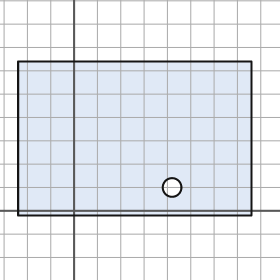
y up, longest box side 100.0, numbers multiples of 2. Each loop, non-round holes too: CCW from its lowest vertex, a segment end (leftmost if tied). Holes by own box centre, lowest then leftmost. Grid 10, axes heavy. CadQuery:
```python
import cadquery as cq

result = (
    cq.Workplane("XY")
    .moveTo(-24.0, -2.0)
    .lineTo(76.0, -2.0)
    .lineTo(76.0, 64.0)
    .lineTo(-24.0, 64.0)
    .close()
    .moveTo(42.0, 10.0)
    .circle(4.0)
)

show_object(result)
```